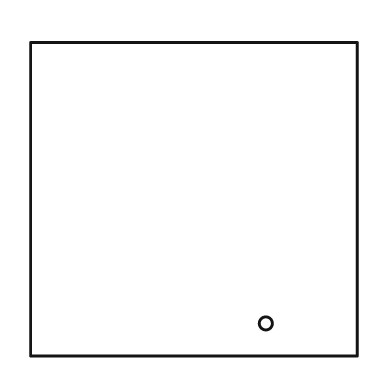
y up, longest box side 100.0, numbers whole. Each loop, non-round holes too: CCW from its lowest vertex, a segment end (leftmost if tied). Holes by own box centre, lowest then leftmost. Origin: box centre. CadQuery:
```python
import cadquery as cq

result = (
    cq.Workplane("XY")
    .moveTo(-50.0, -48.0)
    .lineTo(50.0, -48.0)
    .lineTo(50.0, 48.0)
    .lineTo(-50.0, 48.0)
    .close()
    .moveTo(22.0, -38.0)
    .circle(2.0)
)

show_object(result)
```